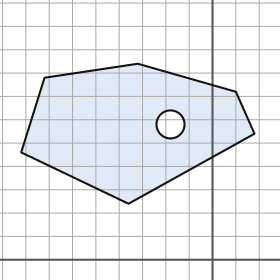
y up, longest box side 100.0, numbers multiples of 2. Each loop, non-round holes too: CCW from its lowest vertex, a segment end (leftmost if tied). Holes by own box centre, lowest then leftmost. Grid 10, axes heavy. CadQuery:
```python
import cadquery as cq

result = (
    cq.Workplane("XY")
    .moveTo(-36.0, 24.0)
    .lineTo(18.0, 54.0)
    .lineTo(10.0, 72.0)
    .lineTo(-32.0, 84.0)
    .lineTo(-72.0, 78.0)
    .lineTo(-82.0, 46.0)
    .close()
    .moveTo(-18.0, 58.0)
    .circle(6.0)
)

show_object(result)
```